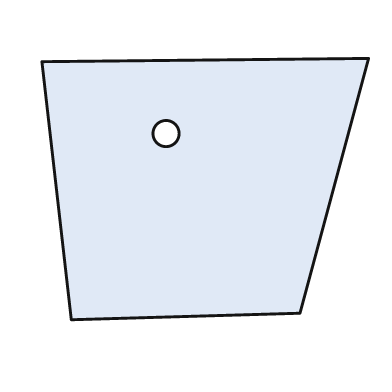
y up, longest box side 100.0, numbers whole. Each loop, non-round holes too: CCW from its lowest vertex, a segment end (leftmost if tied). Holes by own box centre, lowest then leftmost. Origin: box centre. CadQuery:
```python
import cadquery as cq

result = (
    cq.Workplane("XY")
    .moveTo(-41.0, -40.0)
    .lineTo(29.0, -38.0)
    .lineTo(50.0, 40.0)
    .lineTo(-50.0, 39.0)
    .close()
    .moveTo(-12.0, 17.0)
    .circle(4.0)
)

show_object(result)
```